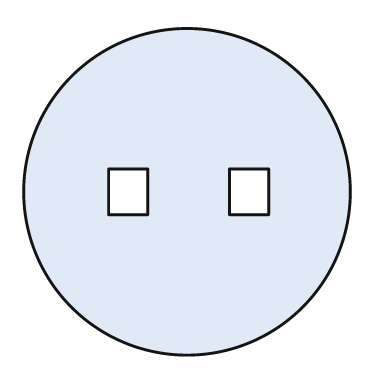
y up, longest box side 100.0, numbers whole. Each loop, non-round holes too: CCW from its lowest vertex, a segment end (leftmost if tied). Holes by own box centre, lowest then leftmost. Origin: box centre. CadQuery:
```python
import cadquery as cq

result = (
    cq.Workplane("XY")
    .moveTo(0.0, 0.0)
    .circle(50.0)
    .moveTo(-24.0, -7.0)
    .lineTo(-12.0, -7.0)
    .lineTo(-12.0, 7.0)
    .lineTo(-24.0, 7.0)
    .close()
    .moveTo(13.0, -7.0)
    .lineTo(25.0, -7.0)
    .lineTo(25.0, 7.0)
    .lineTo(13.0, 7.0)
    .close()
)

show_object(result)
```